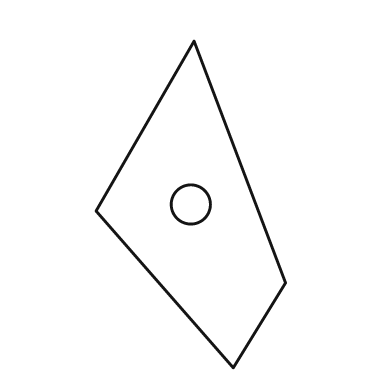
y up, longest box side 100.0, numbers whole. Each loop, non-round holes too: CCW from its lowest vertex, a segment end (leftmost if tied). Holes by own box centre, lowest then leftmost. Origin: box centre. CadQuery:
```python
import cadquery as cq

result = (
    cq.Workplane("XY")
    .moveTo(13.0, -50.0)
    .lineTo(29.0, -24.0)
    .lineTo(1.0, 50.0)
    .lineTo(-29.0, -2.0)
    .close()
    .moveTo(0.0, 0.0)
    .circle(6.0)
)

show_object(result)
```